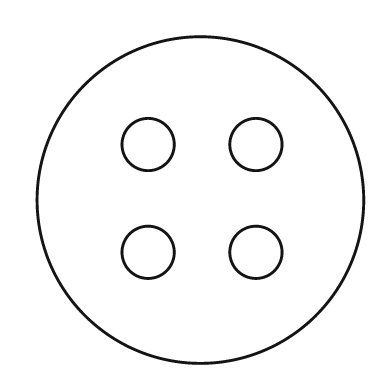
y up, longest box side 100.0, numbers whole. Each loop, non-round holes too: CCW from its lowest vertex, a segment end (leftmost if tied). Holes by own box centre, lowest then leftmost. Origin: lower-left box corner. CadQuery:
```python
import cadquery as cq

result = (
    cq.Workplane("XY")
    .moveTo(50.0, 50.0)
    .circle(50.0)
    .moveTo(34.0, 34.0)
    .circle(8.0)
    .moveTo(67.0, 34.0)
    .circle(8.0)
    .moveTo(34.0, 67.0)
    .circle(8.0)
    .moveTo(67.0, 67.0)
    .circle(8.0)
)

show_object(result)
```